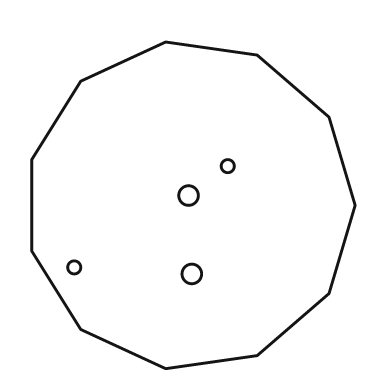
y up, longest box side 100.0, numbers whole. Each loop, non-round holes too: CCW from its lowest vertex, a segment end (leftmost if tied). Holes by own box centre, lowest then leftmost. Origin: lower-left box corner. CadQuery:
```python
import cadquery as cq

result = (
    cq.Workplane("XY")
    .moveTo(41.0, 0.0)
    .lineTo(69.0, 4.0)
    .lineTo(91.0, 23.0)
    .lineTo(99.0, 50.0)
    .lineTo(91.0, 77.0)
    .lineTo(69.0, 96.0)
    .lineTo(41.0, 100.0)
    .lineTo(15.0, 88.0)
    .lineTo(0.0, 64.0)
    .lineTo(0.0, 36.0)
    .lineTo(15.0, 12.0)
    .close()
    .moveTo(49.0, 29.0)
    .circle(3.0)
    .moveTo(13.0, 31.0)
    .circle(2.0)
    .moveTo(48.0, 53.0)
    .circle(3.0)
    .moveTo(60.0, 62.0)
    .circle(2.0)
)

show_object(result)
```